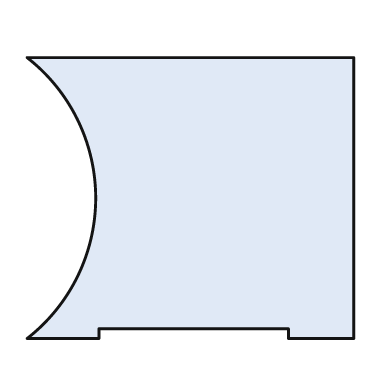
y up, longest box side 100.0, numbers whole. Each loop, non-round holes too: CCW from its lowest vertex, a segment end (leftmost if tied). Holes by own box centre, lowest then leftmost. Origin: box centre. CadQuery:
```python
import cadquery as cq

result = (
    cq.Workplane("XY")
    .moveTo(-50.0, -43.0)
    .lineTo(-28.0, -43.0)
    .lineTo(-28.0, -40.0)
    .lineTo(30.0, -40.0)
    .lineTo(30.0, -43.0)
    .lineTo(50.0, -43.0)
    .lineTo(50.0, 43.0)
    .lineTo(-50.0, 43.0)
    .threePointArc((-29.0, 0.0), (-50.0, -43.0))
    .close()
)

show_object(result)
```